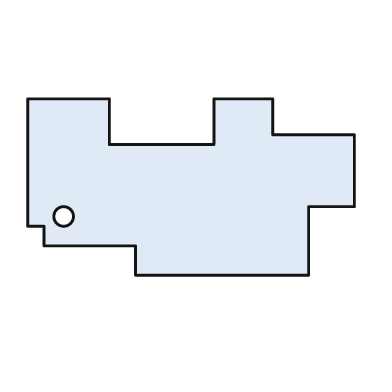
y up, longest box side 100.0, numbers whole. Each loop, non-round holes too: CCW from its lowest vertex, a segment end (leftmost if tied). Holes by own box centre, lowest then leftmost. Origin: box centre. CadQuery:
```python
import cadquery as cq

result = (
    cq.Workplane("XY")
    .moveTo(-17.0, -27.0)
    .lineTo(36.0, -27.0)
    .lineTo(36.0, -6.0)
    .lineTo(50.0, -6.0)
    .lineTo(50.0, 16.0)
    .lineTo(25.0, 16.0)
    .lineTo(25.0, 27.0)
    .lineTo(7.0, 27.0)
    .lineTo(7.0, 13.0)
    .lineTo(-25.0, 13.0)
    .lineTo(-25.0, 27.0)
    .lineTo(-50.0, 27.0)
    .lineTo(-50.0, -12.0)
    .lineTo(-45.0, -12.0)
    .lineTo(-45.0, -18.0)
    .lineTo(-17.0, -18.0)
    .close()
    .moveTo(-39.0, -9.0)
    .circle(3.0)
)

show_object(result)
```